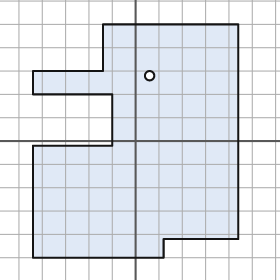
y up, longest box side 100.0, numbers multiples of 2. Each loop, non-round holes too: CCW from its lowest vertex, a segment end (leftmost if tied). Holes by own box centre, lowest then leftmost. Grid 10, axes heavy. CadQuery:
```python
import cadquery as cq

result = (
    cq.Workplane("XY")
    .moveTo(-44.0, -50.0)
    .lineTo(12.0, -50.0)
    .lineTo(12.0, -42.0)
    .lineTo(44.0, -42.0)
    .lineTo(44.0, 50.0)
    .lineTo(-14.0, 50.0)
    .lineTo(-14.0, 30.0)
    .lineTo(-44.0, 30.0)
    .lineTo(-44.0, 20.0)
    .lineTo(-10.0, 20.0)
    .lineTo(-10.0, -2.0)
    .lineTo(-44.0, -2.0)
    .close()
    .moveTo(6.0, 28.0)
    .circle(2.0)
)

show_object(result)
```